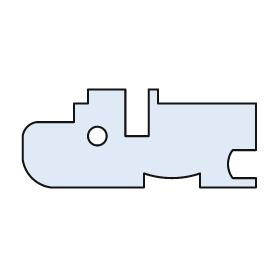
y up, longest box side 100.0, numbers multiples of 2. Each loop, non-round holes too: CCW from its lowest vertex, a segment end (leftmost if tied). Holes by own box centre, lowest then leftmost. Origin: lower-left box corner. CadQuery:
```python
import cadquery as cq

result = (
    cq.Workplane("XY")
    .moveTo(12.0, 0.0)
    .lineTo(52.0, 0.0)
    .lineTo(52.0, 6.0)
    .threePointArc((64.0, 4.0), (76.0, 6.0))
    .lineTo(76.0, 0.0)
    .lineTo(100.0, 0.0)
    .lineTo(100.0, 4.0)
    .lineTo(90.0, 4.0)
    .threePointArc((88.0, 10.0), (90.0, 16.0))
    .lineTo(100.0, 16.0)
    .lineTo(100.0, 36.0)
    .lineTo(58.0, 36.0)
    .lineTo(58.0, 42.0)
    .lineTo(54.0, 42.0)
    .lineTo(54.0, 22.0)
    .lineTo(44.0, 22.0)
    .lineTo(44.0, 42.0)
    .lineTo(28.0, 42.0)
    .lineTo(28.0, 36.0)
    .lineTo(22.0, 36.0)
    .lineTo(22.0, 28.0)
    .lineTo(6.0, 28.0)
    .threePointArc((2.0, 26.0), (0.0, 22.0))
    .lineTo(0.0, 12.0)
    .threePointArc((4.0, 4.0), (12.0, 0.0))
    .close()
    .moveTo(32.0, 22.0)
    .circle(4.0)
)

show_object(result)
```